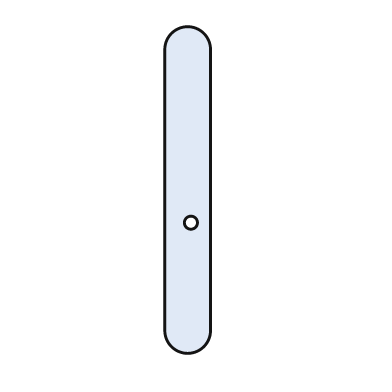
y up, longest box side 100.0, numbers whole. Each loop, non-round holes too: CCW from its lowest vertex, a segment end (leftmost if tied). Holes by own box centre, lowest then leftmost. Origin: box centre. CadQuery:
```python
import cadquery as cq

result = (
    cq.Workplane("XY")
    .moveTo(-7.0, -43.0)
    .threePointArc((0.0, -50.0), (7.0, -43.0))
    .lineTo(7.0, 43.0)
    .threePointArc((0.0, 50.0), (-7.0, 43.0))
    .close()
    .moveTo(1.0, -10.0)
    .circle(2.0)
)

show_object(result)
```